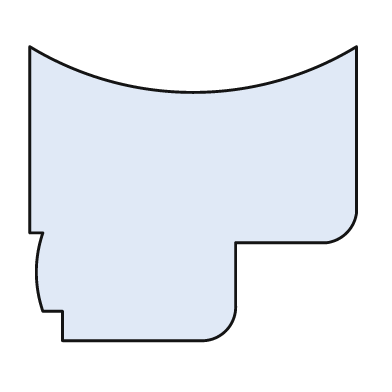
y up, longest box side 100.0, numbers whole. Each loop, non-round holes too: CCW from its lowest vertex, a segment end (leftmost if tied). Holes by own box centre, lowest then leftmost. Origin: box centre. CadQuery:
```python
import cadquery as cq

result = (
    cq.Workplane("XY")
    .moveTo(-40.0, -45.0)
    .lineTo(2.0, -45.0)
    .threePointArc((10.0, -42.0), (13.0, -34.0))
    .lineTo(13.0, -15.0)
    .lineTo(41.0, -15.0)
    .threePointArc((47.0, -12.0), (50.0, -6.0))
    .lineTo(50.0, 45.0)
    .threePointArc((0.0, 31.0), (-50.0, 45.0))
    .lineTo(-50.0, -12.0)
    .lineTo(-46.0, -12.0)
    .threePointArc((-48.0, -24.0), (-46.0, -36.0))
    .lineTo(-40.0, -36.0)
    .close()
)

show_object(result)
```